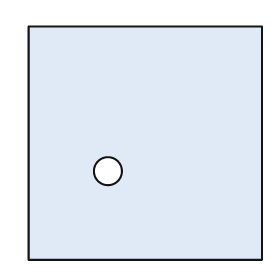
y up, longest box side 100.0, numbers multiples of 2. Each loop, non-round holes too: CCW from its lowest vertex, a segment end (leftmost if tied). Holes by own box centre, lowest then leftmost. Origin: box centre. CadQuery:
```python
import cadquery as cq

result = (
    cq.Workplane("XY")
    .moveTo(-50.0, -50.0)
    .lineTo(50.0, -50.0)
    .lineTo(50.0, 50.0)
    .lineTo(-50.0, 50.0)
    .close()
    .moveTo(-16.0, -12.0)
    .circle(6.0)
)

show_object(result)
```